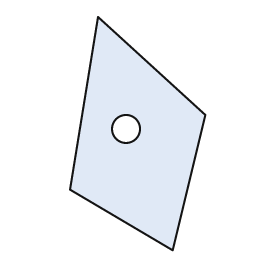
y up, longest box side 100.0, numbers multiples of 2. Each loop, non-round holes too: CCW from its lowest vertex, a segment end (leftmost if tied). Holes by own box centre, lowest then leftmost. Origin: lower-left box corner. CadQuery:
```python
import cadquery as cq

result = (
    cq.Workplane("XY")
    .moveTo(44.0, 0.0)
    .lineTo(58.0, 58.0)
    .lineTo(12.0, 100.0)
    .lineTo(0.0, 26.0)
    .close()
    .moveTo(24.0, 52.0)
    .circle(6.0)
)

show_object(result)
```